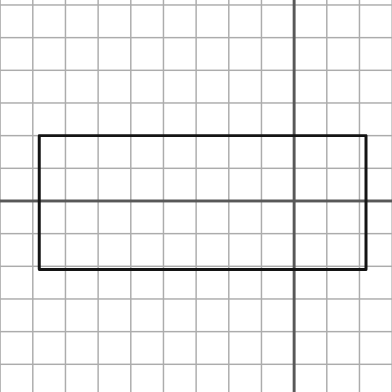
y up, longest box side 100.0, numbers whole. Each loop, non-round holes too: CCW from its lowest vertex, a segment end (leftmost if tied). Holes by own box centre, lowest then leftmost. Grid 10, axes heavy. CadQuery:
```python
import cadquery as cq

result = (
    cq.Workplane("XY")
    .moveTo(-78.0, -21.0)
    .lineTo(22.0, -21.0)
    .lineTo(22.0, 20.0)
    .lineTo(-78.0, 20.0)
    .close()
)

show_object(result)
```